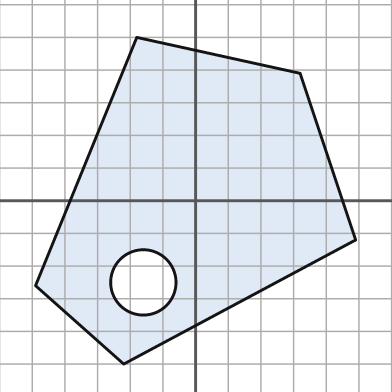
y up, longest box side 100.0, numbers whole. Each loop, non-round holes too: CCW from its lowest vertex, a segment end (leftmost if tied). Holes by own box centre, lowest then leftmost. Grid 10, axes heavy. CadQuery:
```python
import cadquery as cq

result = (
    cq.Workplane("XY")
    .moveTo(-22.0, -50.0)
    .lineTo(49.0, -12.0)
    .lineTo(32.0, 39.0)
    .lineTo(-18.0, 50.0)
    .lineTo(-49.0, -26.0)
    .close()
    .moveTo(-16.0, -25.0)
    .circle(10.0)
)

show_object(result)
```